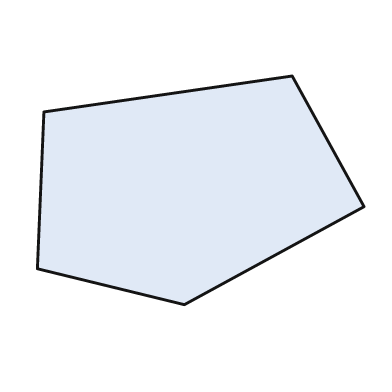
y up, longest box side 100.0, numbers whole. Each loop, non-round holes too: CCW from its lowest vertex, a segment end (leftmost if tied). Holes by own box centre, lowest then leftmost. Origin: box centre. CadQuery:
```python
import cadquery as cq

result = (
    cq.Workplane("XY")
    .moveTo(-5.0, -35.0)
    .lineTo(50.0, -5.0)
    .lineTo(28.0, 35.0)
    .lineTo(-48.0, 24.0)
    .lineTo(-50.0, -24.0)
    .close()
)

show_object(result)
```